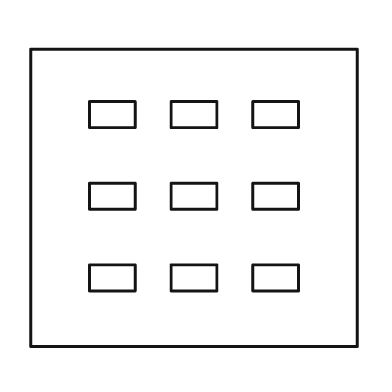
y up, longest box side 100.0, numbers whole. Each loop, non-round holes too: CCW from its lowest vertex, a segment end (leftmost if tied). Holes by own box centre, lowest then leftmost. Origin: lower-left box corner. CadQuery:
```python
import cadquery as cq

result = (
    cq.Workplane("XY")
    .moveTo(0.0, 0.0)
    .lineTo(100.0, 0.0)
    .lineTo(100.0, 91.0)
    .lineTo(0.0, 91.0)
    .close()
    .moveTo(18.0, 17.0)
    .lineTo(32.0, 17.0)
    .lineTo(32.0, 25.0)
    .lineTo(18.0, 25.0)
    .close()
    .moveTo(43.0, 17.0)
    .lineTo(57.0, 17.0)
    .lineTo(57.0, 25.0)
    .lineTo(43.0, 25.0)
    .close()
    .moveTo(68.0, 17.0)
    .lineTo(82.0, 17.0)
    .lineTo(82.0, 25.0)
    .lineTo(68.0, 25.0)
    .close()
    .moveTo(18.0, 42.0)
    .lineTo(32.0, 42.0)
    .lineTo(32.0, 50.0)
    .lineTo(18.0, 50.0)
    .close()
    .moveTo(43.0, 42.0)
    .lineTo(57.0, 42.0)
    .lineTo(57.0, 50.0)
    .lineTo(43.0, 50.0)
    .close()
    .moveTo(68.0, 42.0)
    .lineTo(82.0, 42.0)
    .lineTo(82.0, 50.0)
    .lineTo(68.0, 50.0)
    .close()
    .moveTo(18.0, 67.0)
    .lineTo(32.0, 67.0)
    .lineTo(32.0, 75.0)
    .lineTo(18.0, 75.0)
    .close()
    .moveTo(43.0, 67.0)
    .lineTo(57.0, 67.0)
    .lineTo(57.0, 75.0)
    .lineTo(43.0, 75.0)
    .close()
    .moveTo(68.0, 67.0)
    .lineTo(82.0, 67.0)
    .lineTo(82.0, 75.0)
    .lineTo(68.0, 75.0)
    .close()
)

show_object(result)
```